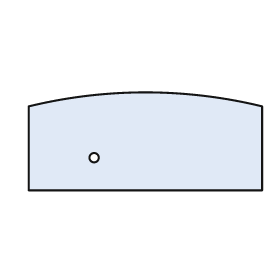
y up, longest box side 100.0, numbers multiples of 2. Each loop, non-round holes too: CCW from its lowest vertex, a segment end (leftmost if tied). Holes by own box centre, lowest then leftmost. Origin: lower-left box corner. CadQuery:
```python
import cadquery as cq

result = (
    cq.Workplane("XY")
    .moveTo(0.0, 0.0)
    .lineTo(100.0, 0.0)
    .lineTo(100.0, 36.0)
    .threePointArc((50.0, 42.0), (0.0, 36.0))
    .close()
    .moveTo(28.0, 14.0)
    .circle(2.0)
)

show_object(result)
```